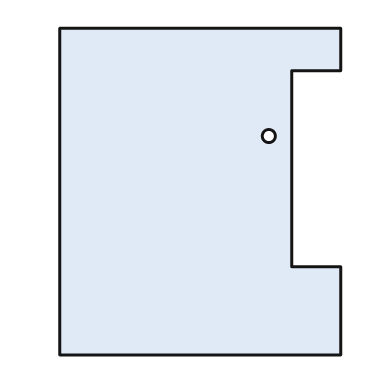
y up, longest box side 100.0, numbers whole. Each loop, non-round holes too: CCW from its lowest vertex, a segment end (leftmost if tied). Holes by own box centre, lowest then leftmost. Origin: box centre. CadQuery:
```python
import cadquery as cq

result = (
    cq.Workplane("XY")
    .moveTo(-43.0, -50.0)
    .lineTo(43.0, -50.0)
    .lineTo(43.0, -23.0)
    .lineTo(28.0, -23.0)
    .lineTo(28.0, 37.0)
    .lineTo(43.0, 37.0)
    .lineTo(43.0, 50.0)
    .lineTo(-43.0, 50.0)
    .close()
    .moveTo(21.0, 17.0)
    .circle(2.0)
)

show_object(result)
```